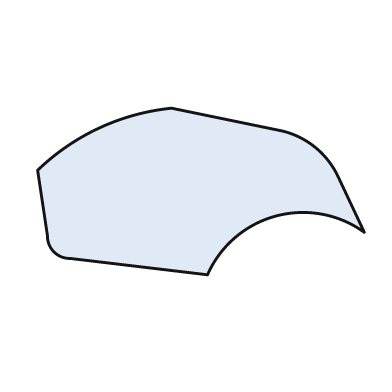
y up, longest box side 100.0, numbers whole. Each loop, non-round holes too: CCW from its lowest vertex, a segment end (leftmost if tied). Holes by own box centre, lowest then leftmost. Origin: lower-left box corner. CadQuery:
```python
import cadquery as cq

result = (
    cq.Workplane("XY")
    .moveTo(52.0, 0.0)
    .threePointArc((73.0, 18.0), (100.0, 13.0))
    .lineTo(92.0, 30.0)
    .threePointArc((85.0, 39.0), (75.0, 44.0))
    .lineTo(41.0, 51.0)
    .threePointArc((19.0, 45.0), (0.0, 32.0))
    .lineTo(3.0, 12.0)
    .threePointArc((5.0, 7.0), (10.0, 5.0))
    .close()
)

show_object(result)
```